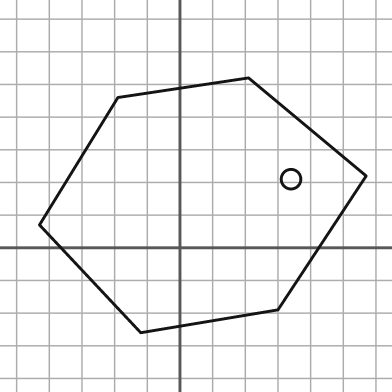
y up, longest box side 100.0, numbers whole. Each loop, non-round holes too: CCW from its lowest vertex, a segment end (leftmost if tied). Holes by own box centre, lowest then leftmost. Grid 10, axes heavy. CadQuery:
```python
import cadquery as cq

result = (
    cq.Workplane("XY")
    .moveTo(-12.0, -26.0)
    .lineTo(30.0, -19.0)
    .lineTo(57.0, 22.0)
    .lineTo(21.0, 52.0)
    .lineTo(-19.0, 46.0)
    .lineTo(-43.0, 7.0)
    .close()
    .moveTo(34.0, 21.0)
    .circle(3.0)
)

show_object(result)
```